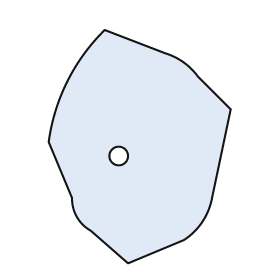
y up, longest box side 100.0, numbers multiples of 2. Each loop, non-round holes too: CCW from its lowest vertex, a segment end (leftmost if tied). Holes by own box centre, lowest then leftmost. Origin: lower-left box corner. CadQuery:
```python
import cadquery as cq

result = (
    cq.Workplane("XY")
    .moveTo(34.0, 0.0)
    .lineTo(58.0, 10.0)
    .threePointArc((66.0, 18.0), (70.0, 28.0))
    .lineTo(78.0, 66.0)
    .lineTo(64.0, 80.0)
    .threePointArc((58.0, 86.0), (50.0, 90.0))
    .lineTo(24.0, 100.0)
    .threePointArc((8.0, 78.0), (0.0, 52.0))
    .lineTo(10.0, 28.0)
    .threePointArc((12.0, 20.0), (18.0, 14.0))
    .close()
    .moveTo(30.0, 46.0)
    .circle(4.0)
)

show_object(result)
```